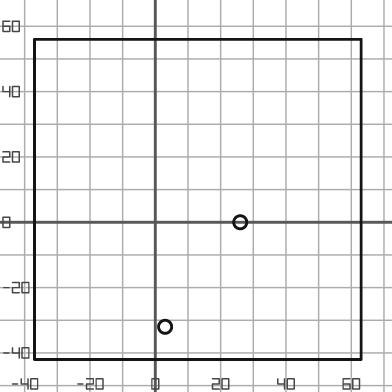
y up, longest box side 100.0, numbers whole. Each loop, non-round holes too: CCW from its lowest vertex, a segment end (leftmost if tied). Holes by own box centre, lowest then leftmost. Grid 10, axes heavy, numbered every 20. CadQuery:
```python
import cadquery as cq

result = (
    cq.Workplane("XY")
    .moveTo(-37.0, -42.0)
    .lineTo(63.0, -42.0)
    .lineTo(63.0, 56.0)
    .lineTo(-37.0, 56.0)
    .close()
    .moveTo(3.0, -32.0)
    .circle(2.0)
    .moveTo(26.0, 0.0)
    .circle(2.0)
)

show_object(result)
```